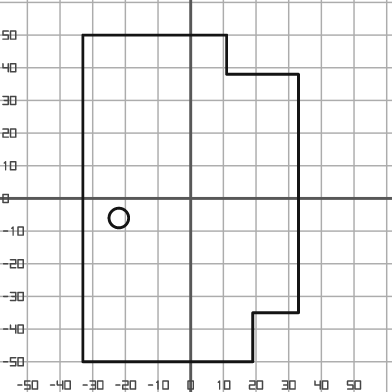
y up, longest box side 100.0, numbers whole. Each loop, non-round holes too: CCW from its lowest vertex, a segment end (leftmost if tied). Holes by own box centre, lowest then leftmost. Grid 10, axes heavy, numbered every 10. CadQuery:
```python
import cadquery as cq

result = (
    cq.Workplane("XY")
    .moveTo(-33.0, -50.0)
    .lineTo(19.0, -50.0)
    .lineTo(19.0, -35.0)
    .lineTo(33.0, -35.0)
    .lineTo(33.0, 38.0)
    .lineTo(11.0, 38.0)
    .lineTo(11.0, 50.0)
    .lineTo(-33.0, 50.0)
    .close()
    .moveTo(-22.0, -6.0)
    .circle(3.0)
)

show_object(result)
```